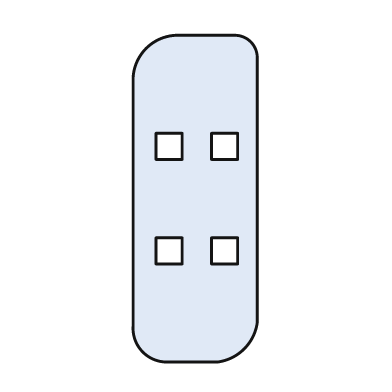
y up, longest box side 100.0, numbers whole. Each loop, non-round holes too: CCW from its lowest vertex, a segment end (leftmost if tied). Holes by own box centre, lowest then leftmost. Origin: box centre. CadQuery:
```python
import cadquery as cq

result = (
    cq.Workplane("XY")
    .moveTo(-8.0, -50.0)
    .lineTo(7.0, -50.0)
    .threePointArc((15.0, -46.0), (19.0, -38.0))
    .lineTo(19.0, 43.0)
    .threePointArc((17.0, 48.0), (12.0, 50.0))
    .lineTo(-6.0, 50.0)
    .threePointArc((-15.0, 46.0), (-19.0, 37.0))
    .lineTo(-19.0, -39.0)
    .threePointArc((-16.0, -47.0), (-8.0, -50.0))
    .close()
    .moveTo(-12.0, -20.0)
    .lineTo(-4.0, -20.0)
    .lineTo(-4.0, -12.0)
    .lineTo(-12.0, -12.0)
    .close()
    .moveTo(5.0, -20.0)
    .lineTo(13.0, -20.0)
    .lineTo(13.0, -12.0)
    .lineTo(5.0, -12.0)
    .close()
    .moveTo(-12.0, 12.0)
    .lineTo(-4.0, 12.0)
    .lineTo(-4.0, 20.0)
    .lineTo(-12.0, 20.0)
    .close()
    .moveTo(5.0, 12.0)
    .lineTo(13.0, 12.0)
    .lineTo(13.0, 20.0)
    .lineTo(5.0, 20.0)
    .close()
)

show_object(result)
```